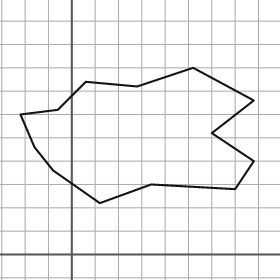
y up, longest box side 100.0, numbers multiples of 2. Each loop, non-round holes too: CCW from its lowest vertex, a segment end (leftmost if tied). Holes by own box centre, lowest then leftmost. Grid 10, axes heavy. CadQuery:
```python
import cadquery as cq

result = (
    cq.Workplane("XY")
    .moveTo(12.0, 22.0)
    .lineTo(34.0, 30.0)
    .lineTo(70.0, 28.0)
    .lineTo(78.0, 40.0)
    .lineTo(60.0, 52.0)
    .lineTo(78.0, 66.0)
    .lineTo(52.0, 80.0)
    .lineTo(28.0, 72.0)
    .lineTo(6.0, 74.0)
    .lineTo(-6.0, 62.0)
    .lineTo(-22.0, 60.0)
    .lineTo(-16.0, 46.0)
    .lineTo(-8.0, 36.0)
    .close()
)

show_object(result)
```